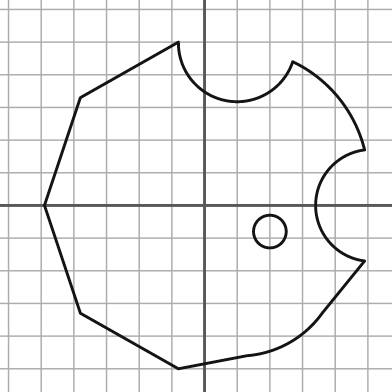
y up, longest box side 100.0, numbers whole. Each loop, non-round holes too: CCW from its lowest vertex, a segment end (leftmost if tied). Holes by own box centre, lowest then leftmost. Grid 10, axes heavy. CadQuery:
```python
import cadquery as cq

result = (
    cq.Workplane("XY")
    .moveTo(-8.0, -50.0)
    .lineTo(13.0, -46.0)
    .threePointArc((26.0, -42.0), (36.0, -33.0))
    .lineTo(49.0, -17.0)
    .threePointArc((34.0, 0.0), (49.0, 17.0))
    .threePointArc((41.0, 33.0), (27.0, 44.0))
    .threePointArc((7.0, 32.0), (-8.0, 50.0))
    .lineTo(-38.0, 33.0)
    .lineTo(-49.0, 0.0)
    .lineTo(-38.0, -33.0)
    .close()
    .moveTo(20.0, -8.0)
    .circle(5.0)
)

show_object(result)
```